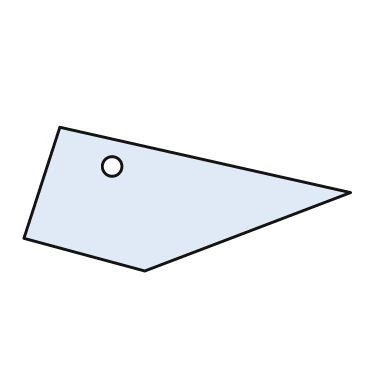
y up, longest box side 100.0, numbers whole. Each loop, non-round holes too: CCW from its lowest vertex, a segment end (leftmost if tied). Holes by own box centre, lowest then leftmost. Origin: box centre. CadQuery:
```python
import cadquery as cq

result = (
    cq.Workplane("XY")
    .moveTo(-13.0, -22.0)
    .lineTo(50.0, 2.0)
    .lineTo(-39.0, 22.0)
    .lineTo(-50.0, -12.0)
    .close()
    .moveTo(-23.0, 10.0)
    .circle(3.0)
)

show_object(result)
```